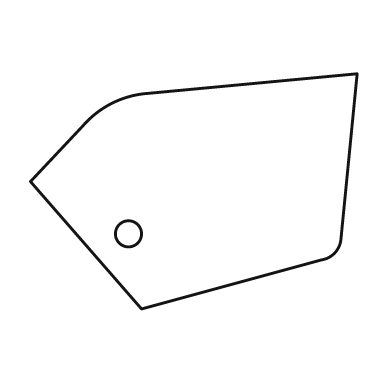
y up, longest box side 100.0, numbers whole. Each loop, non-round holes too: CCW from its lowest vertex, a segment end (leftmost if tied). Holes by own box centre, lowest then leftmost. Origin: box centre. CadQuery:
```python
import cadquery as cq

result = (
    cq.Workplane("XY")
    .moveTo(-16.0, -36.0)
    .lineTo(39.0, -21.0)
    .threePointArc((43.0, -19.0), (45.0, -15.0))
    .lineTo(50.0, 36.0)
    .lineTo(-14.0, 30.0)
    .threePointArc((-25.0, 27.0), (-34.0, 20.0))
    .lineTo(-50.0, 3.0)
    .close()
    .moveTo(-20.0, -13.0)
    .circle(4.0)
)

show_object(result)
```